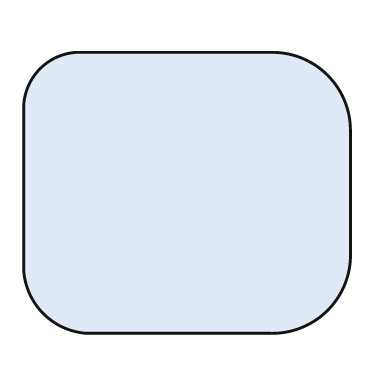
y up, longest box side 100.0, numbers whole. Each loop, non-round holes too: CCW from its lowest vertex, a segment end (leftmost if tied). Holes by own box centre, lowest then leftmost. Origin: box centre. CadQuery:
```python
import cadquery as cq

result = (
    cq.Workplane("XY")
    .moveTo(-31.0, -43.0)
    .lineTo(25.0, -43.0)
    .threePointArc((43.0, -36.0), (50.0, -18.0))
    .lineTo(50.0, 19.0)
    .threePointArc((43.0, 36.0), (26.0, 43.0))
    .lineTo(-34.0, 43.0)
    .threePointArc((-45.0, 38.0), (-50.0, 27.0))
    .lineTo(-50.0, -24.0)
    .threePointArc((-44.0, -37.0), (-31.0, -43.0))
    .close()
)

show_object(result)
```